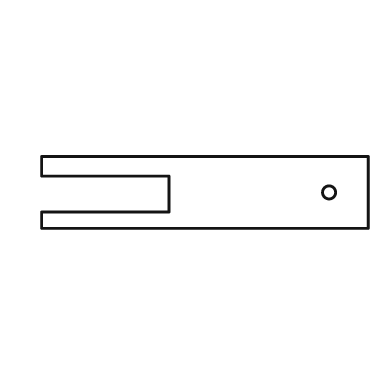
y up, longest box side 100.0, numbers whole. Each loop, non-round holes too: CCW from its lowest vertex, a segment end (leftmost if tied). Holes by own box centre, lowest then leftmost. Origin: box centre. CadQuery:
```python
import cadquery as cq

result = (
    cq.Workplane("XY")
    .moveTo(-50.0, -11.0)
    .lineTo(50.0, -11.0)
    .lineTo(50.0, 11.0)
    .lineTo(-50.0, 11.0)
    .lineTo(-50.0, 5.0)
    .lineTo(-11.0, 5.0)
    .lineTo(-11.0, -6.0)
    .lineTo(-50.0, -6.0)
    .close()
    .moveTo(38.0, 0.0)
    .circle(2.0)
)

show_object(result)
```